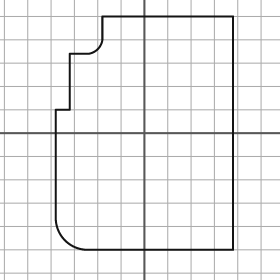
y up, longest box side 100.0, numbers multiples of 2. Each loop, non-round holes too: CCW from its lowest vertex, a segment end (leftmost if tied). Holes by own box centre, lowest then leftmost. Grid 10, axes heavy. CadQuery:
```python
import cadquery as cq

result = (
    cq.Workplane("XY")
    .moveTo(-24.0, -50.0)
    .lineTo(38.0, -50.0)
    .lineTo(38.0, 50.0)
    .lineTo(-18.0, 50.0)
    .lineTo(-18.0, 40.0)
    .threePointArc((-20.0, 36.0), (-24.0, 34.0))
    .lineTo(-32.0, 34.0)
    .lineTo(-32.0, 10.0)
    .lineTo(-38.0, 10.0)
    .lineTo(-38.0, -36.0)
    .threePointArc((-34.0, -46.0), (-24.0, -50.0))
    .close()
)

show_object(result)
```